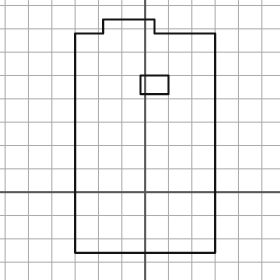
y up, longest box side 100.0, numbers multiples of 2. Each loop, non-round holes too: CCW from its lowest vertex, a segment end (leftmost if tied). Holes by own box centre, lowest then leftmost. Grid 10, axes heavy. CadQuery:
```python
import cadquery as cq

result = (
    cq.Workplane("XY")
    .moveTo(-30.0, -26.0)
    .lineTo(30.0, -26.0)
    .lineTo(30.0, 68.0)
    .lineTo(4.0, 68.0)
    .lineTo(4.0, 74.0)
    .lineTo(-18.0, 74.0)
    .lineTo(-18.0, 68.0)
    .lineTo(-30.0, 68.0)
    .close()
    .moveTo(-2.0, 42.0)
    .lineTo(10.0, 42.0)
    .lineTo(10.0, 50.0)
    .lineTo(-2.0, 50.0)
    .close()
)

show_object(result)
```